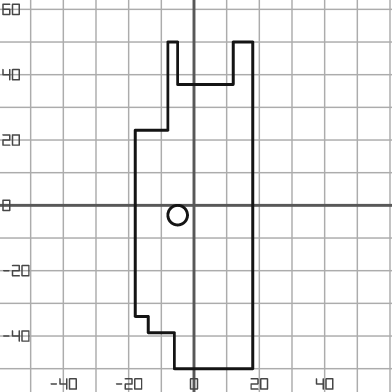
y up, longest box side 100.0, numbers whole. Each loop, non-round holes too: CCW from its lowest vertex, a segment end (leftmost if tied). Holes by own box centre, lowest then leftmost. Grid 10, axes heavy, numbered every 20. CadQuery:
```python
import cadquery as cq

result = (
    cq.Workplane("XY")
    .moveTo(-6.0, -50.0)
    .lineTo(18.0, -50.0)
    .lineTo(18.0, 50.0)
    .lineTo(12.0, 50.0)
    .lineTo(12.0, 37.0)
    .lineTo(-5.0, 37.0)
    .lineTo(-5.0, 50.0)
    .lineTo(-8.0, 50.0)
    .lineTo(-8.0, 23.0)
    .lineTo(-18.0, 23.0)
    .lineTo(-18.0, -34.0)
    .lineTo(-14.0, -34.0)
    .lineTo(-14.0, -39.0)
    .lineTo(-6.0, -39.0)
    .close()
    .moveTo(-5.0, -3.0)
    .circle(3.0)
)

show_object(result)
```